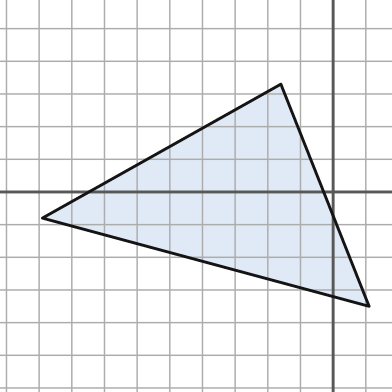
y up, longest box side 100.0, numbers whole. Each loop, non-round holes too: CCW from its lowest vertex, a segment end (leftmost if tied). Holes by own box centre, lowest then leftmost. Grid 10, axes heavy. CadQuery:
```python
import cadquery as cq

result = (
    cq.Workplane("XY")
    .moveTo(11.0, -35.0)
    .lineTo(-16.0, 33.0)
    .lineTo(-89.0, -8.0)
    .close()
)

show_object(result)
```